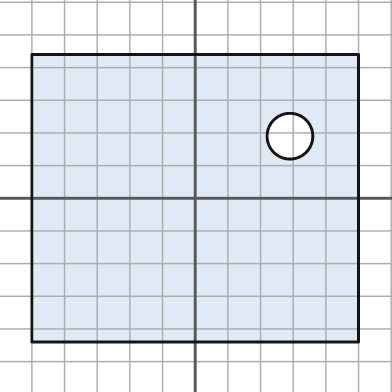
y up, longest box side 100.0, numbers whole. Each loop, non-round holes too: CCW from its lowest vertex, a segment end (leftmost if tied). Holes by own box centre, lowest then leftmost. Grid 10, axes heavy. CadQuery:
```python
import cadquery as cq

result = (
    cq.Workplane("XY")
    .moveTo(-50.0, -44.0)
    .lineTo(50.0, -44.0)
    .lineTo(50.0, 44.0)
    .lineTo(-50.0, 44.0)
    .close()
    .moveTo(29.0, 19.0)
    .circle(7.0)
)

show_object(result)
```